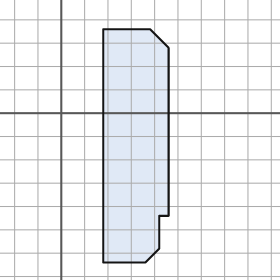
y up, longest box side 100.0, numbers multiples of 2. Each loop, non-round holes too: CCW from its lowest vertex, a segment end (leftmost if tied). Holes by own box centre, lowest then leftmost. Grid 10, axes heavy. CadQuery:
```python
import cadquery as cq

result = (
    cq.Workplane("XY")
    .moveTo(18.0, -64.0)
    .lineTo(36.0, -64.0)
    .lineTo(42.0, -58.0)
    .lineTo(42.0, -44.0)
    .lineTo(46.0, -44.0)
    .lineTo(46.0, 28.0)
    .lineTo(38.0, 36.0)
    .lineTo(18.0, 36.0)
    .close()
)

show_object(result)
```